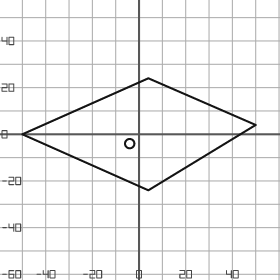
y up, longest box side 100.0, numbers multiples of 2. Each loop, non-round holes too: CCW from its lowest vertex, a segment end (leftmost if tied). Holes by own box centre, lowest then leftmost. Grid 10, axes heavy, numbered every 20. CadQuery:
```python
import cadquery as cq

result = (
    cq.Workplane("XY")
    .moveTo(4.0, -24.0)
    .lineTo(50.0, 4.0)
    .lineTo(4.0, 24.0)
    .lineTo(-50.0, 0.0)
    .close()
    .moveTo(-4.0, -4.0)
    .circle(2.0)
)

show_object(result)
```